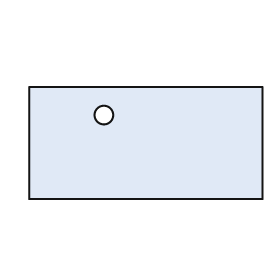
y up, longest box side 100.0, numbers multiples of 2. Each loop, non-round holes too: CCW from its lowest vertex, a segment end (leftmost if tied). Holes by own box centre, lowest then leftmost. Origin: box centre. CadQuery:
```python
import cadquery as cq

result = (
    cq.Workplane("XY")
    .moveTo(-50.0, -24.0)
    .lineTo(50.0, -24.0)
    .lineTo(50.0, 24.0)
    .lineTo(-50.0, 24.0)
    .close()
    .moveTo(-18.0, 12.0)
    .circle(4.0)
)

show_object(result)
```